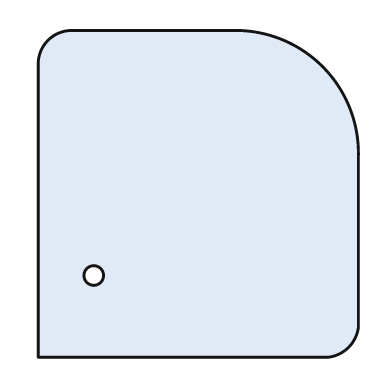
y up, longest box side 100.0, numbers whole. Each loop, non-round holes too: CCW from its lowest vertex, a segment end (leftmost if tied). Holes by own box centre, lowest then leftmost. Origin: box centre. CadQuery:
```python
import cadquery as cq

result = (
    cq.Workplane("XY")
    .moveTo(-49.0, -50.0)
    .lineTo(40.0, -50.0)
    .threePointArc((46.0, -47.0), (49.0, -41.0))
    .lineTo(49.0, 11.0)
    .threePointArc((38.0, 39.0), (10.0, 50.0))
    .lineTo(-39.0, 50.0)
    .threePointArc((-46.0, 47.0), (-49.0, 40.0))
    .close()
    .moveTo(-32.0, -25.0)
    .circle(3.0)
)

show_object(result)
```